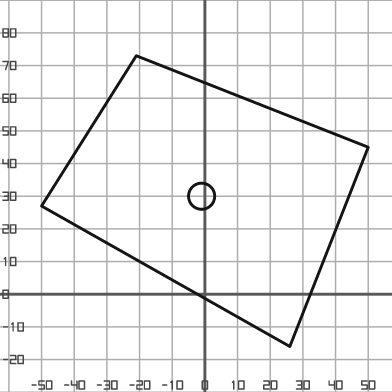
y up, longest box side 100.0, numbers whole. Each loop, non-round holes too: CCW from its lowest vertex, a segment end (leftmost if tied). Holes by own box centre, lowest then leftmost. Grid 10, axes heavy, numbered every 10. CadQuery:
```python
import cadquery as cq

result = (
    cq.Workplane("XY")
    .moveTo(26.0, -16.0)
    .lineTo(50.0, 45.0)
    .lineTo(-21.0, 73.0)
    .lineTo(-50.0, 27.0)
    .close()
    .moveTo(-1.0, 30.0)
    .circle(4.0)
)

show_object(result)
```